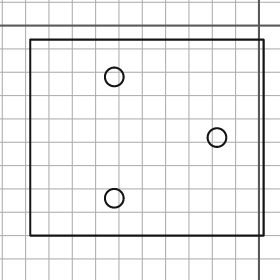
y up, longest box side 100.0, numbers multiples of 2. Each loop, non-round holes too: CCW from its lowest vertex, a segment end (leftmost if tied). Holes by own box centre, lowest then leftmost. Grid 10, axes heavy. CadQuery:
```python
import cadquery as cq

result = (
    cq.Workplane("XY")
    .moveTo(-98.0, -90.0)
    .lineTo(2.0, -90.0)
    .lineTo(2.0, -6.0)
    .lineTo(-98.0, -6.0)
    .close()
    .moveTo(-62.0, -74.0)
    .circle(4.0)
    .moveTo(-18.0, -48.0)
    .circle(4.0)
    .moveTo(-62.0, -22.0)
    .circle(4.0)
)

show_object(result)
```